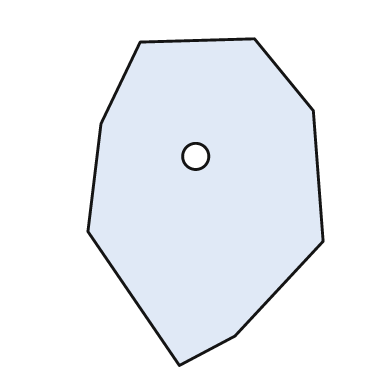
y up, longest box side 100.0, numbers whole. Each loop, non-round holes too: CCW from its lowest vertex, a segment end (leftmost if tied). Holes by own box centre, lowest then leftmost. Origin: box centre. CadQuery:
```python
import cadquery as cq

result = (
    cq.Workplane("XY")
    .moveTo(-8.0, -50.0)
    .lineTo(9.0, -41.0)
    .lineTo(36.0, -12.0)
    .lineTo(33.0, 28.0)
    .lineTo(15.0, 50.0)
    .lineTo(-20.0, 49.0)
    .lineTo(-32.0, 24.0)
    .lineTo(-36.0, -9.0)
    .close()
    .moveTo(-3.0, 14.0)
    .circle(4.0)
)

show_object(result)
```